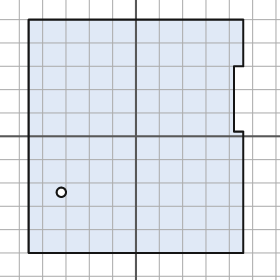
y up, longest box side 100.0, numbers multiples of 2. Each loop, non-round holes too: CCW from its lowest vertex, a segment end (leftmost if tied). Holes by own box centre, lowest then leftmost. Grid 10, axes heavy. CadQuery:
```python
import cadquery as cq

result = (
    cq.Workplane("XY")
    .moveTo(-46.0, -50.0)
    .lineTo(46.0, -50.0)
    .lineTo(46.0, 2.0)
    .lineTo(42.0, 2.0)
    .lineTo(42.0, 30.0)
    .lineTo(46.0, 30.0)
    .lineTo(46.0, 50.0)
    .lineTo(-46.0, 50.0)
    .close()
    .moveTo(-32.0, -24.0)
    .circle(2.0)
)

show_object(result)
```